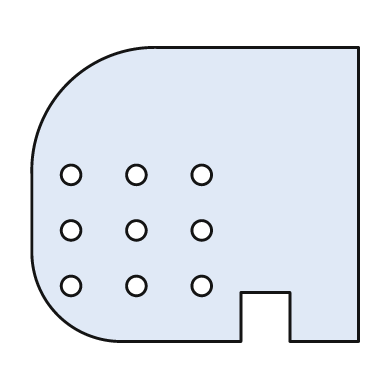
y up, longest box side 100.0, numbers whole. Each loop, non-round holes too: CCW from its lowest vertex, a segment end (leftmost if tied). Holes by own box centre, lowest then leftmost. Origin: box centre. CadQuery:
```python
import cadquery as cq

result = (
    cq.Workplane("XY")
    .moveTo(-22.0, -45.0)
    .lineTo(14.0, -45.0)
    .lineTo(14.0, -30.0)
    .lineTo(29.0, -30.0)
    .lineTo(29.0, -45.0)
    .lineTo(50.0, -45.0)
    .lineTo(50.0, 45.0)
    .lineTo(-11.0, 45.0)
    .threePointArc((-39.0, 34.0), (-50.0, 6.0))
    .lineTo(-50.0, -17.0)
    .threePointArc((-42.0, -37.0), (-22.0, -45.0))
    .close()
    .moveTo(-38.0, -28.0)
    .circle(3.0)
    .moveTo(-18.0, -28.0)
    .circle(3.0)
    .moveTo(2.0, -28.0)
    .circle(3.0)
    .moveTo(-38.0, -11.0)
    .circle(3.0)
    .moveTo(-18.0, -11.0)
    .circle(3.0)
    .moveTo(2.0, -11.0)
    .circle(3.0)
    .moveTo(-38.0, 6.0)
    .circle(3.0)
    .moveTo(-18.0, 6.0)
    .circle(3.0)
    .moveTo(2.0, 6.0)
    .circle(3.0)
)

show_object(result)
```